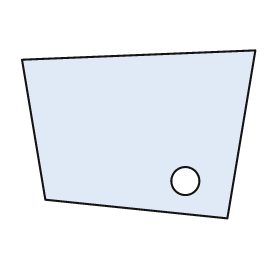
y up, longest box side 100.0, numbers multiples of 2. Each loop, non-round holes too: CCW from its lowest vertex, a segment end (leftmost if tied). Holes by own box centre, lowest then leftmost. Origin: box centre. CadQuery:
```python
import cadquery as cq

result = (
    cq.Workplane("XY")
    .moveTo(38.0, -36.0)
    .lineTo(50.0, 36.0)
    .lineTo(-50.0, 32.0)
    .lineTo(-40.0, -28.0)
    .close()
    .moveTo(20.0, -20.0)
    .circle(6.0)
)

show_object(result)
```